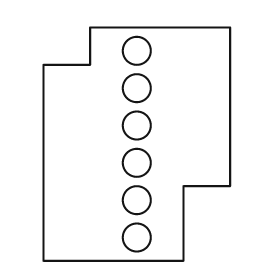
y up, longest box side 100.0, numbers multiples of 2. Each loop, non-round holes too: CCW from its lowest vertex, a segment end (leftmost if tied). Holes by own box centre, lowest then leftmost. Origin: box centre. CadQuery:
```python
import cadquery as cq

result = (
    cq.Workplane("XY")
    .moveTo(-40.0, -50.0)
    .lineTo(20.0, -50.0)
    .lineTo(20.0, -18.0)
    .lineTo(40.0, -18.0)
    .lineTo(40.0, 50.0)
    .lineTo(-20.0, 50.0)
    .lineTo(-20.0, 34.0)
    .lineTo(-40.0, 34.0)
    .close()
    .moveTo(0.0, -40.0)
    .circle(6.0)
    .moveTo(0.0, -24.0)
    .circle(6.0)
    .moveTo(0.0, -8.0)
    .circle(6.0)
    .moveTo(0.0, 8.0)
    .circle(6.0)
    .moveTo(0.0, 24.0)
    .circle(6.0)
    .moveTo(0.0, 40.0)
    .circle(6.0)
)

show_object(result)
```